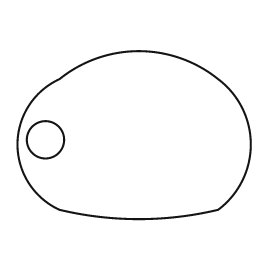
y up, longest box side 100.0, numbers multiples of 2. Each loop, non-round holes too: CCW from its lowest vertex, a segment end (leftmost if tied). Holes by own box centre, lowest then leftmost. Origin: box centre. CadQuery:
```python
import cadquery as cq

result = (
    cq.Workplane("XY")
    .moveTo(-32.0, -32.0)
    .threePointArc((2.0, -36.0), (36.0, -32.0))
    .threePointArc((50.0, -4.0), (36.0, 24.0))
    .threePointArc((2.0, 36.0), (-32.0, 24.0))
    .threePointArc((-50.0, -4.0), (-32.0, -32.0))
    .close()
    .moveTo(-38.0, -2.0)
    .circle(8.0)
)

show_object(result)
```